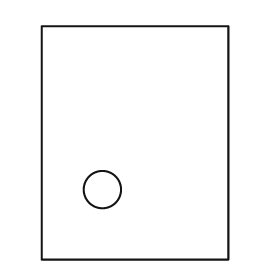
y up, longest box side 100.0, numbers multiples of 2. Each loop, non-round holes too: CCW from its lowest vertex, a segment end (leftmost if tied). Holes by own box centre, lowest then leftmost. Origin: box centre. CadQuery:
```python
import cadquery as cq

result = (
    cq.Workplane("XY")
    .moveTo(-40.0, -50.0)
    .lineTo(40.0, -50.0)
    .lineTo(40.0, 50.0)
    .lineTo(-40.0, 50.0)
    .close()
    .moveTo(-14.0, -20.0)
    .circle(8.0)
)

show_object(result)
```